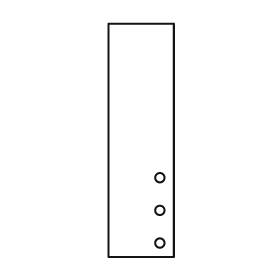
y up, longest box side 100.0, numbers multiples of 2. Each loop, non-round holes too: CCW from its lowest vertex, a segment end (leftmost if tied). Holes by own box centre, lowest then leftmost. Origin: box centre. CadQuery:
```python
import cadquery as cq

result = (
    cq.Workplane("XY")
    .moveTo(-14.0, -50.0)
    .lineTo(14.0, -50.0)
    .lineTo(14.0, 50.0)
    .lineTo(-14.0, 50.0)
    .close()
    .moveTo(8.0, -44.0)
    .circle(2.0)
    .moveTo(8.0, -30.0)
    .circle(2.0)
    .moveTo(8.0, -16.0)
    .circle(2.0)
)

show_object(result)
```